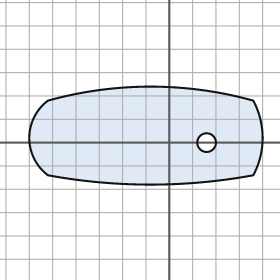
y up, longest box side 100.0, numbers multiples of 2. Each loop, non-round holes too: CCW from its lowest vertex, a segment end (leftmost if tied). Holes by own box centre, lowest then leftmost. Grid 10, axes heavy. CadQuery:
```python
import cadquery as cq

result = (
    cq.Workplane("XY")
    .moveTo(-52.0, -14.0)
    .threePointArc((-8.0, -18.0), (36.0, -14.0))
    .threePointArc((40.0, 2.0), (36.0, 18.0))
    .threePointArc((-8.0, 24.0), (-52.0, 18.0))
    .threePointArc((-60.0, 2.0), (-52.0, -14.0))
    .close()
    .moveTo(16.0, 0.0)
    .circle(4.0)
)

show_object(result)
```